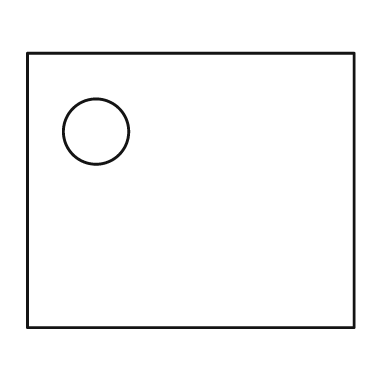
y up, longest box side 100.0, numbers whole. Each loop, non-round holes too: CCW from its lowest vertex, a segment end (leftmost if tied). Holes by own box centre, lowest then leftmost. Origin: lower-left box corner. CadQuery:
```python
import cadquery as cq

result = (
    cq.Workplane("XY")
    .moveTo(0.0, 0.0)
    .lineTo(100.0, 0.0)
    .lineTo(100.0, 84.0)
    .lineTo(0.0, 84.0)
    .close()
    .moveTo(21.0, 60.0)
    .circle(10.0)
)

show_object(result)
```